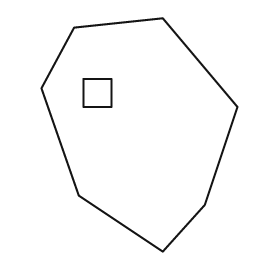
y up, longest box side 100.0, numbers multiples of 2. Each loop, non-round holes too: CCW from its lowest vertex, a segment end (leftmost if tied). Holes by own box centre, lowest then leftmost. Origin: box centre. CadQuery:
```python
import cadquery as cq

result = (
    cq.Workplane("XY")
    .moveTo(10.0, -50.0)
    .lineTo(28.0, -30.0)
    .lineTo(42.0, 12.0)
    .lineTo(10.0, 50.0)
    .lineTo(-28.0, 46.0)
    .lineTo(-42.0, 20.0)
    .lineTo(-26.0, -26.0)
    .close()
    .moveTo(-24.0, 12.0)
    .lineTo(-12.0, 12.0)
    .lineTo(-12.0, 24.0)
    .lineTo(-24.0, 24.0)
    .close()
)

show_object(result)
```